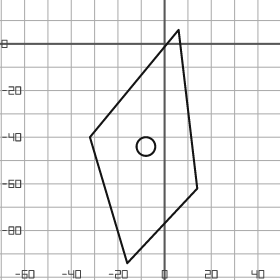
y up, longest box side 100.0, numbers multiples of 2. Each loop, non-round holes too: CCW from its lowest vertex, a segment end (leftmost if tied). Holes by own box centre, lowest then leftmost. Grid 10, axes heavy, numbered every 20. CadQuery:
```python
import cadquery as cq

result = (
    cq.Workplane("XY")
    .moveTo(-16.0, -94.0)
    .lineTo(14.0, -62.0)
    .lineTo(6.0, 6.0)
    .lineTo(-32.0, -40.0)
    .close()
    .moveTo(-8.0, -44.0)
    .circle(4.0)
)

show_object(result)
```